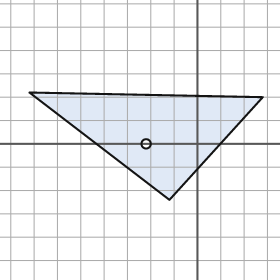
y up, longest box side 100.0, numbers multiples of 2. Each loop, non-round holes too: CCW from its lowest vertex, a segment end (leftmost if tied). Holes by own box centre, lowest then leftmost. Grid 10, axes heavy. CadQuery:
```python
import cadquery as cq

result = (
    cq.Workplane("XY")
    .moveTo(-12.0, -24.0)
    .lineTo(28.0, 20.0)
    .lineTo(-72.0, 22.0)
    .close()
    .moveTo(-22.0, 0.0)
    .circle(2.0)
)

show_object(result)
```